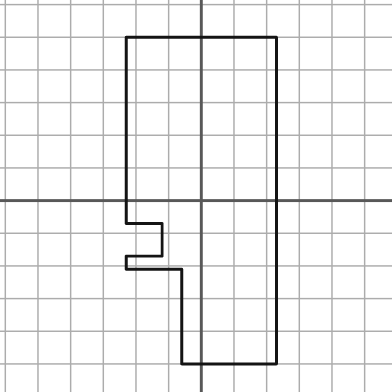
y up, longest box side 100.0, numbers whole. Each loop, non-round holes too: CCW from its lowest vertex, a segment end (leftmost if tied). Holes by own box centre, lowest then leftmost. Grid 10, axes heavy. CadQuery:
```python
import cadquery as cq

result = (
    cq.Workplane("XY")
    .moveTo(-6.0, -50.0)
    .lineTo(23.0, -50.0)
    .lineTo(23.0, 50.0)
    .lineTo(-23.0, 50.0)
    .lineTo(-23.0, -7.0)
    .lineTo(-12.0, -7.0)
    .lineTo(-12.0, -17.0)
    .lineTo(-23.0, -17.0)
    .lineTo(-23.0, -21.0)
    .lineTo(-6.0, -21.0)
    .close()
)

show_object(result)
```